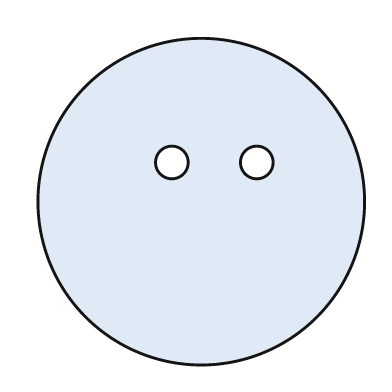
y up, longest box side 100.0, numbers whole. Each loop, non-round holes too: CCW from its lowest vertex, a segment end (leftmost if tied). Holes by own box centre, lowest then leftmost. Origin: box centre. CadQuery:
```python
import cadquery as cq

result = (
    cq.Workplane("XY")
    .moveTo(0.0, 0.0)
    .circle(50.0)
    .moveTo(-9.0, 12.0)
    .circle(5.0)
    .moveTo(17.0, 12.0)
    .circle(5.0)
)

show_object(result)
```